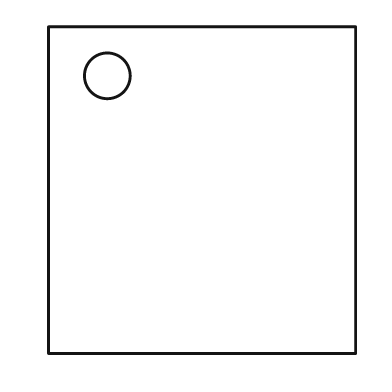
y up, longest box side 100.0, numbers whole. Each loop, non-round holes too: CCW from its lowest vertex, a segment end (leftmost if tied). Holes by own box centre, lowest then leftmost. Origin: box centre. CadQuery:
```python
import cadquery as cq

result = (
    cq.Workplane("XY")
    .moveTo(-47.0, -50.0)
    .lineTo(47.0, -50.0)
    .lineTo(47.0, 50.0)
    .lineTo(-47.0, 50.0)
    .close()
    .moveTo(-29.0, 35.0)
    .circle(7.0)
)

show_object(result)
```